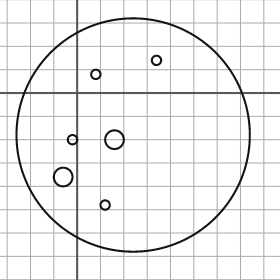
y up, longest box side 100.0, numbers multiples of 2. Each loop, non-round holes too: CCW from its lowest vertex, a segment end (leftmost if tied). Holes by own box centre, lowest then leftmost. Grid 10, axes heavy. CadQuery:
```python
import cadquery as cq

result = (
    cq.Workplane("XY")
    .moveTo(24.0, -18.0)
    .circle(50.0)
    .moveTo(12.0, -48.0)
    .circle(2.0)
    .moveTo(-6.0, -36.0)
    .circle(4.0)
    .moveTo(-2.0, -20.0)
    .circle(2.0)
    .moveTo(16.0, -20.0)
    .circle(4.0)
    .moveTo(8.0, 8.0)
    .circle(2.0)
    .moveTo(34.0, 14.0)
    .circle(2.0)
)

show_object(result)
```